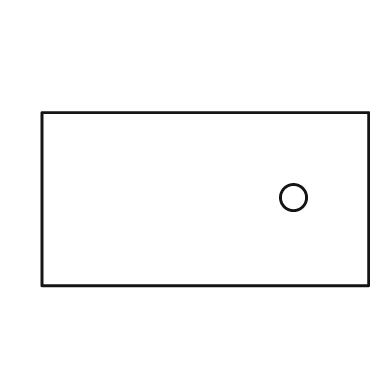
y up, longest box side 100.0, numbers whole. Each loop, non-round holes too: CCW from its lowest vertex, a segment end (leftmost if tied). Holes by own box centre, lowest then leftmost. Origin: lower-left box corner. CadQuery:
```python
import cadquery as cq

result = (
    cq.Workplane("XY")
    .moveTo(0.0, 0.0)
    .lineTo(100.0, 0.0)
    .lineTo(100.0, 53.0)
    .lineTo(0.0, 53.0)
    .close()
    .moveTo(77.0, 27.0)
    .circle(4.0)
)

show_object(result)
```